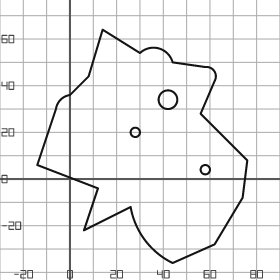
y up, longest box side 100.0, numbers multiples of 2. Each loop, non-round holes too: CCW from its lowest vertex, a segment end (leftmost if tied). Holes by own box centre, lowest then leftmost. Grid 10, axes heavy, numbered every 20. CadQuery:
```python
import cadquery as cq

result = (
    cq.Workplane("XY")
    .moveTo(44.0, -36.0)
    .lineTo(62.0, -28.0)
    .lineTo(74.0, -8.0)
    .lineTo(76.0, 8.0)
    .lineTo(56.0, 28.0)
    .lineTo(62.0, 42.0)
    .threePointArc((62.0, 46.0), (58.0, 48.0))
    .lineTo(44.0, 50.0)
    .threePointArc((38.0, 56.0), (30.0, 54.0))
    .lineTo(14.0, 64.0)
    .lineTo(8.0, 44.0)
    .lineTo(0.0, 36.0)
    .threePointArc((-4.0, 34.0), (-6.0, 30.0))
    .lineTo(-14.0, 6.0)
    .lineTo(12.0, -4.0)
    .lineTo(6.0, -22.0)
    .lineTo(26.0, -12.0)
    .threePointArc((32.0, -26.0), (44.0, -36.0))
    .close()
    .moveTo(58.0, 4.0)
    .circle(2.0)
    .moveTo(28.0, 20.0)
    .circle(2.0)
    .moveTo(42.0, 34.0)
    .circle(4.0)
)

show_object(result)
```